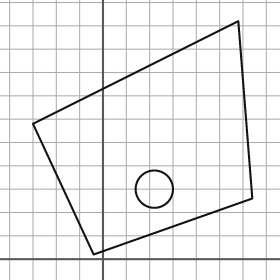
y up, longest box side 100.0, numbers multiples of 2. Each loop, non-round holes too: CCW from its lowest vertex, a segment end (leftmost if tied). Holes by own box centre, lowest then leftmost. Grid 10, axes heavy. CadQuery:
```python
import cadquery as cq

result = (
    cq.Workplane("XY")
    .moveTo(-4.0, 2.0)
    .lineTo(64.0, 26.0)
    .lineTo(58.0, 102.0)
    .lineTo(-30.0, 58.0)
    .close()
    .moveTo(22.0, 30.0)
    .circle(8.0)
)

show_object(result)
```